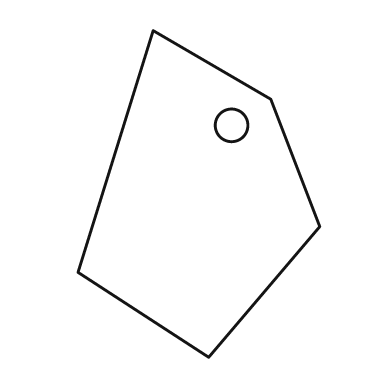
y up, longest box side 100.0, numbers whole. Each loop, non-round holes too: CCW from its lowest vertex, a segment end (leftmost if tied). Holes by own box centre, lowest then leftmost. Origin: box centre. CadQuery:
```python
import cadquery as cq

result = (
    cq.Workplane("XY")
    .moveTo(3.0, -50.0)
    .lineTo(37.0, -10.0)
    .lineTo(22.0, 29.0)
    .lineTo(-14.0, 50.0)
    .lineTo(-37.0, -24.0)
    .close()
    .moveTo(10.0, 21.0)
    .circle(5.0)
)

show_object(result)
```